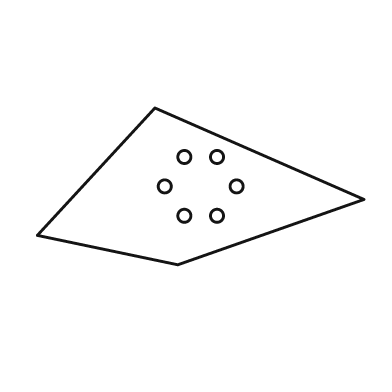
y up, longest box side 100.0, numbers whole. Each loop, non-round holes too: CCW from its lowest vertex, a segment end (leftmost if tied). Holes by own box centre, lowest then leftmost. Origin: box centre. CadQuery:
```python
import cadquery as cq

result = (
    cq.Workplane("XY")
    .moveTo(-7.0, -24.0)
    .lineTo(50.0, -4.0)
    .lineTo(-14.0, 24.0)
    .lineTo(-50.0, -15.0)
    .close()
    .moveTo(-5.0, -9.0)
    .circle(2.0)
    .moveTo(5.0, -9.0)
    .circle(2.0)
    .moveTo(-11.0, 0.0)
    .circle(2.0)
    .moveTo(11.0, 0.0)
    .circle(2.0)
    .moveTo(-5.0, 9.0)
    .circle(2.0)
    .moveTo(5.0, 9.0)
    .circle(2.0)
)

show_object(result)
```